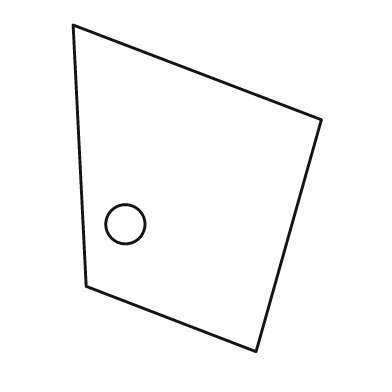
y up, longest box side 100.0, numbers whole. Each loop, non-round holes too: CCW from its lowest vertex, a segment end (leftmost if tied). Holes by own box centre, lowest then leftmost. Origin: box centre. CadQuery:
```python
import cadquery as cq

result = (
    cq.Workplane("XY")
    .moveTo(18.0, -50.0)
    .lineTo(38.0, 21.0)
    .lineTo(-38.0, 50.0)
    .lineTo(-34.0, -30.0)
    .close()
    .moveTo(-22.0, -11.0)
    .circle(6.0)
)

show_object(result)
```